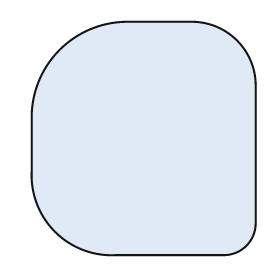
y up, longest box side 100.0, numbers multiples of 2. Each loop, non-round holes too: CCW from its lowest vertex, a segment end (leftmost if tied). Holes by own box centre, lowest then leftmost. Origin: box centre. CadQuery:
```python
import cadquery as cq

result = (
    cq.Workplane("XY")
    .moveTo(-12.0, -50.0)
    .lineTo(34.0, -50.0)
    .threePointArc((44.0, -46.0), (48.0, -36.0))
    .lineTo(48.0, 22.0)
    .threePointArc((40.0, 42.0), (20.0, 50.0))
    .lineTo(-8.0, 50.0)
    .threePointArc((-36.0, 38.0), (-48.0, 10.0))
    .lineTo(-48.0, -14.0)
    .threePointArc((-38.0, -40.0), (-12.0, -50.0))
    .close()
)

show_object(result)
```